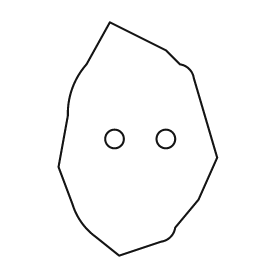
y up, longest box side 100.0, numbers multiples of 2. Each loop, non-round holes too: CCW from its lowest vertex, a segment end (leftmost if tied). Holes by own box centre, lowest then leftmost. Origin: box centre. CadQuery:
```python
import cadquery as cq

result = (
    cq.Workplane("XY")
    .moveTo(-8.0, -50.0)
    .lineTo(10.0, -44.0)
    .threePointArc((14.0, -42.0), (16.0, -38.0))
    .lineTo(26.0, -26.0)
    .lineTo(34.0, -8.0)
    .lineTo(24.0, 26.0)
    .threePointArc((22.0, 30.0), (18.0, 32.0))
    .lineTo(12.0, 38.0)
    .lineTo(-12.0, 50.0)
    .lineTo(-22.0, 32.0)
    .threePointArc((-28.0, 22.0), (-30.0, 10.0))
    .lineTo(-34.0, -12.0)
    .lineTo(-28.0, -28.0)
    .threePointArc((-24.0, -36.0), (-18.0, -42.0))
    .close()
    .moveTo(-10.0, 0.0)
    .circle(4.0)
    .moveTo(12.0, 0.0)
    .circle(4.0)
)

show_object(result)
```